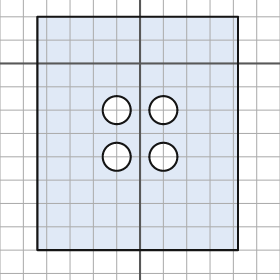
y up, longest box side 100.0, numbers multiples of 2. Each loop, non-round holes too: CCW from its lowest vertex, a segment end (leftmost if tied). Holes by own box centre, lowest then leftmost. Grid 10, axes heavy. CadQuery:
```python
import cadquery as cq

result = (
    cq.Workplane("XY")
    .moveTo(-44.0, -80.0)
    .lineTo(42.0, -80.0)
    .lineTo(42.0, 20.0)
    .lineTo(-44.0, 20.0)
    .close()
    .moveTo(-10.0, -40.0)
    .circle(6.0)
    .moveTo(10.0, -40.0)
    .circle(6.0)
    .moveTo(-10.0, -20.0)
    .circle(6.0)
    .moveTo(10.0, -20.0)
    .circle(6.0)
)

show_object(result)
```